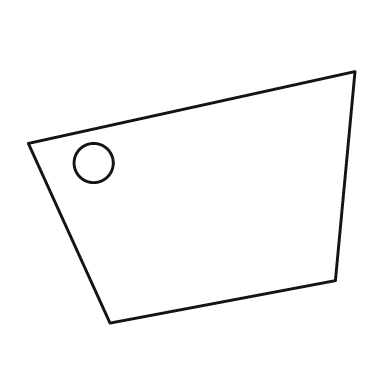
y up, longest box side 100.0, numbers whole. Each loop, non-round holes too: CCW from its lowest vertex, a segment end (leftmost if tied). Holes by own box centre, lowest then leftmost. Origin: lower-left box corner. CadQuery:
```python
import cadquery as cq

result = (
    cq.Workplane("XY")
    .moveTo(25.0, 0.0)
    .lineTo(94.0, 13.0)
    .lineTo(100.0, 77.0)
    .lineTo(0.0, 55.0)
    .close()
    .moveTo(20.0, 49.0)
    .circle(6.0)
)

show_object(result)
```